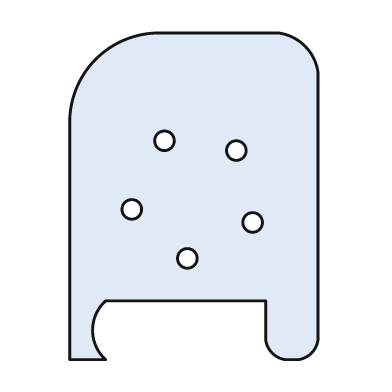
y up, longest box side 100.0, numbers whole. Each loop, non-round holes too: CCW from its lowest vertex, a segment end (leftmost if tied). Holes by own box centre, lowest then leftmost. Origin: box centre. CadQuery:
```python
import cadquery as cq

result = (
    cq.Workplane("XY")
    .moveTo(-38.0, -50.0)
    .lineTo(-27.0, -50.0)
    .threePointArc((-31.0, -41.0), (-27.0, -32.0))
    .lineTo(22.0, -32.0)
    .lineTo(22.0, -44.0)
    .threePointArc((24.0, -48.0), (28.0, -50.0))
    .lineTo(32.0, -50.0)
    .threePointArc((36.0, -48.0), (38.0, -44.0))
    .lineTo(38.0, 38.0)
    .threePointArc((34.0, 46.0), (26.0, 50.0))
    .lineTo(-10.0, 50.0)
    .threePointArc((-30.0, 42.0), (-38.0, 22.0))
    .close()
    .moveTo(-2.0, -19.0)
    .circle(3.0)
    .moveTo(18.0, -8.0)
    .circle(3.0)
    .moveTo(-19.0, -4.0)
    .circle(3.0)
    .moveTo(13.0, 14.0)
    .circle(3.0)
    .moveTo(-9.0, 17.0)
    .circle(3.0)
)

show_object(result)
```